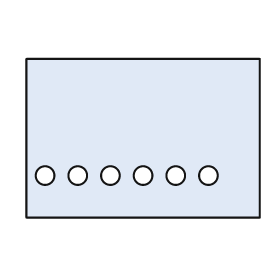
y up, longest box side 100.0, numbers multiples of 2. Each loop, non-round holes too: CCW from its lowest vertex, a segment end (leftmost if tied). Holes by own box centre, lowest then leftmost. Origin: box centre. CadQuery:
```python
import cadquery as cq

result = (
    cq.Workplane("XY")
    .moveTo(-50.0, -34.0)
    .lineTo(50.0, -34.0)
    .lineTo(50.0, 34.0)
    .lineTo(-50.0, 34.0)
    .close()
    .moveTo(-42.0, -16.0)
    .circle(4.0)
    .moveTo(-28.0, -16.0)
    .circle(4.0)
    .moveTo(-14.0, -16.0)
    .circle(4.0)
    .moveTo(0.0, -16.0)
    .circle(4.0)
    .moveTo(14.0, -16.0)
    .circle(4.0)
    .moveTo(28.0, -16.0)
    .circle(4.0)
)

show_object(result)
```